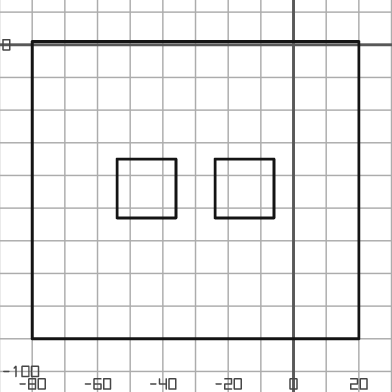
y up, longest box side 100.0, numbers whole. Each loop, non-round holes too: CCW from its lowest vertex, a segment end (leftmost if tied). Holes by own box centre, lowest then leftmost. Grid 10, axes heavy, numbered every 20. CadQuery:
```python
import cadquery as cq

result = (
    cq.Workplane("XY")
    .moveTo(-80.0, -90.0)
    .lineTo(20.0, -90.0)
    .lineTo(20.0, 1.0)
    .lineTo(-80.0, 1.0)
    .close()
    .moveTo(-54.0, -53.0)
    .lineTo(-36.0, -53.0)
    .lineTo(-36.0, -35.0)
    .lineTo(-54.0, -35.0)
    .close()
    .moveTo(-24.0, -53.0)
    .lineTo(-6.0, -53.0)
    .lineTo(-6.0, -35.0)
    .lineTo(-24.0, -35.0)
    .close()
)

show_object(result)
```